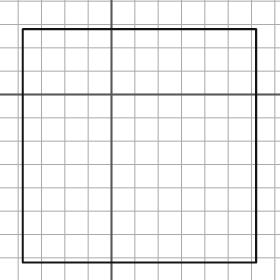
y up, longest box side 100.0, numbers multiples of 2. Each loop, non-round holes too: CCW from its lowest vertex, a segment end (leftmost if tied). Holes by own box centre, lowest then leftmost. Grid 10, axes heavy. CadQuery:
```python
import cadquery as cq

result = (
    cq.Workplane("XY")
    .moveTo(-38.0, -72.0)
    .lineTo(62.0, -72.0)
    .lineTo(62.0, 28.0)
    .lineTo(-38.0, 28.0)
    .close()
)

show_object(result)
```